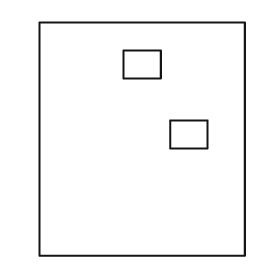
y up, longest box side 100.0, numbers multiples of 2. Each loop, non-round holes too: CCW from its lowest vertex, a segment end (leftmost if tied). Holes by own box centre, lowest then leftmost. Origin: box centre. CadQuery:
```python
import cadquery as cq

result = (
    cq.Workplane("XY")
    .moveTo(-44.0, -50.0)
    .lineTo(44.0, -50.0)
    .lineTo(44.0, 50.0)
    .lineTo(-44.0, 50.0)
    .close()
    .moveTo(12.0, -4.0)
    .lineTo(28.0, -4.0)
    .lineTo(28.0, 8.0)
    .lineTo(12.0, 8.0)
    .close()
    .moveTo(-8.0, 26.0)
    .lineTo(8.0, 26.0)
    .lineTo(8.0, 38.0)
    .lineTo(-8.0, 38.0)
    .close()
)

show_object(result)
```